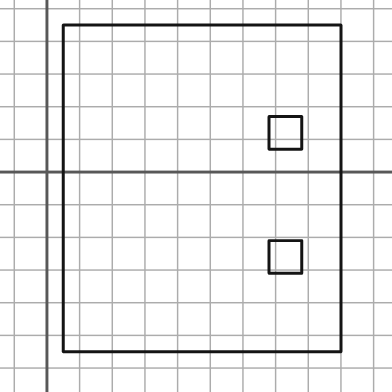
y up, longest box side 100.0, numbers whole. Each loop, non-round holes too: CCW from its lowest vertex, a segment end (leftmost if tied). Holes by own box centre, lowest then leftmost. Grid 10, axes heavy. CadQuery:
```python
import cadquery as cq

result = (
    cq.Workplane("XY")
    .moveTo(5.0, -55.0)
    .lineTo(90.0, -55.0)
    .lineTo(90.0, 45.0)
    .lineTo(5.0, 45.0)
    .close()
    .moveTo(68.0, -31.0)
    .lineTo(78.0, -31.0)
    .lineTo(78.0, -21.0)
    .lineTo(68.0, -21.0)
    .close()
    .moveTo(68.0, 7.0)
    .lineTo(78.0, 7.0)
    .lineTo(78.0, 17.0)
    .lineTo(68.0, 17.0)
    .close()
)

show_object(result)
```